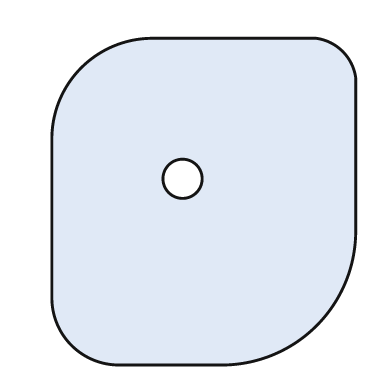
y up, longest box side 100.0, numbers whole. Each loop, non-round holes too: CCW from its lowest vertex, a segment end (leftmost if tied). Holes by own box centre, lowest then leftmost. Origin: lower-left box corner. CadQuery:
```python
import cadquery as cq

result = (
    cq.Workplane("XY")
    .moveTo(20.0, 0.0)
    .lineTo(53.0, 0.0)
    .threePointArc((81.0, 12.0), (93.0, 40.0))
    .lineTo(93.0, 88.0)
    .threePointArc((89.0, 96.0), (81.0, 100.0))
    .lineTo(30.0, 100.0)
    .threePointArc((9.0, 91.0), (0.0, 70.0))
    .lineTo(0.0, 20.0)
    .threePointArc((6.0, 6.0), (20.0, 0.0))
    .close()
    .moveTo(40.0, 57.0)
    .circle(6.0)
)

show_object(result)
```